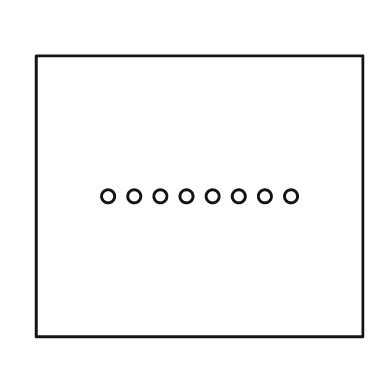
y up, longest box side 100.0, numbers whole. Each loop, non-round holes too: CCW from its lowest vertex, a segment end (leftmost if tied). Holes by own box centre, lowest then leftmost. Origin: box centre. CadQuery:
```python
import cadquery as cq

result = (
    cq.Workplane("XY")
    .moveTo(-50.0, -43.0)
    .lineTo(50.0, -43.0)
    .lineTo(50.0, 43.0)
    .lineTo(-50.0, 43.0)
    .close()
    .moveTo(-28.0, 0.0)
    .circle(2.0)
    .moveTo(-20.0, 0.0)
    .circle(2.0)
    .moveTo(-12.0, 0.0)
    .circle(2.0)
    .moveTo(-4.0, 0.0)
    .circle(2.0)
    .moveTo(4.0, 0.0)
    .circle(2.0)
    .moveTo(12.0, 0.0)
    .circle(2.0)
    .moveTo(20.0, 0.0)
    .circle(2.0)
    .moveTo(28.0, 0.0)
    .circle(2.0)
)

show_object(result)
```